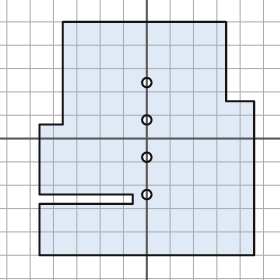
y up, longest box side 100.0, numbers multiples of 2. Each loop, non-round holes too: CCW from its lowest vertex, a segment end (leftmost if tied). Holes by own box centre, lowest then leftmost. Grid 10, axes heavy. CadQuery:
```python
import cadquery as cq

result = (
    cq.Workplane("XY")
    .moveTo(-46.0, -50.0)
    .lineTo(46.0, -50.0)
    .lineTo(46.0, 16.0)
    .lineTo(34.0, 16.0)
    .lineTo(34.0, 50.0)
    .lineTo(-36.0, 50.0)
    .lineTo(-36.0, 6.0)
    .lineTo(-46.0, 6.0)
    .lineTo(-46.0, -24.0)
    .lineTo(-6.0, -24.0)
    .lineTo(-6.0, -28.0)
    .lineTo(-46.0, -28.0)
    .close()
    .moveTo(0.0, -24.0)
    .circle(2.0)
    .moveTo(0.0, -8.0)
    .circle(2.0)
    .moveTo(0.0, 8.0)
    .circle(2.0)
    .moveTo(0.0, 24.0)
    .circle(2.0)
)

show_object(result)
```